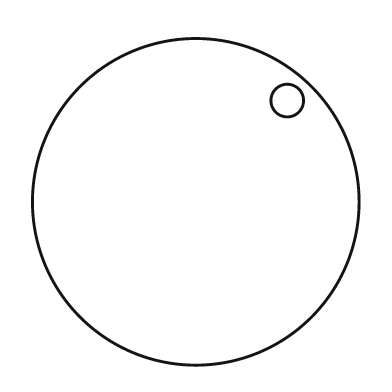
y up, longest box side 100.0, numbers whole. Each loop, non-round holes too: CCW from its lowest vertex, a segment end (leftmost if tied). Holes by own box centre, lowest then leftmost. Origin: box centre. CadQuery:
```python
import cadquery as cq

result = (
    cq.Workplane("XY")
    .moveTo(0.0, 0.0)
    .circle(50.0)
    .moveTo(28.0, 31.0)
    .circle(5.0)
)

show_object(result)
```